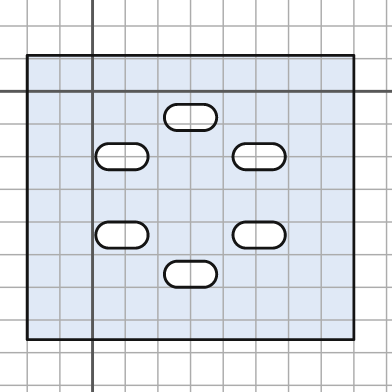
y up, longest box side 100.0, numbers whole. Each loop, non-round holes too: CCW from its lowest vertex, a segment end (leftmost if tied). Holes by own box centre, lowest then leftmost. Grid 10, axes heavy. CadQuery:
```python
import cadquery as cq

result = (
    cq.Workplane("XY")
    .moveTo(-20.0, -76.0)
    .lineTo(80.0, -76.0)
    .lineTo(80.0, 11.0)
    .lineTo(-20.0, 11.0)
    .close()
    .moveTo(26.0, -60.0)
    .lineTo(34.0, -60.0)
    .threePointArc((38.0, -56.0), (34.0, -52.0))
    .lineTo(26.0, -52.0)
    .threePointArc((22.0, -56.0), (26.0, -60.0))
    .close()
    .moveTo(5.0, -48.0)
    .lineTo(13.0, -48.0)
    .threePointArc((17.0, -44.0), (13.0, -40.0))
    .lineTo(5.0, -40.0)
    .threePointArc((1.0, -44.0), (5.0, -48.0))
    .close()
    .moveTo(47.0, -48.0)
    .lineTo(55.0, -48.0)
    .threePointArc((59.0, -44.0), (55.0, -40.0))
    .lineTo(47.0, -40.0)
    .threePointArc((43.0, -44.0), (47.0, -48.0))
    .close()
    .moveTo(5.0, -24.0)
    .lineTo(13.0, -24.0)
    .threePointArc((17.0, -20.0), (13.0, -16.0))
    .lineTo(5.0, -16.0)
    .threePointArc((1.0, -20.0), (5.0, -24.0))
    .close()
    .moveTo(47.0, -24.0)
    .lineTo(55.0, -24.0)
    .threePointArc((59.0, -20.0), (55.0, -16.0))
    .lineTo(47.0, -16.0)
    .threePointArc((43.0, -20.0), (47.0, -24.0))
    .close()
    .moveTo(26.0, -12.0)
    .lineTo(34.0, -12.0)
    .threePointArc((38.0, -8.0), (34.0, -4.0))
    .lineTo(26.0, -4.0)
    .threePointArc((22.0, -8.0), (26.0, -12.0))
    .close()
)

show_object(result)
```